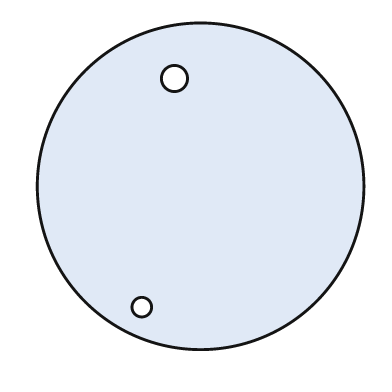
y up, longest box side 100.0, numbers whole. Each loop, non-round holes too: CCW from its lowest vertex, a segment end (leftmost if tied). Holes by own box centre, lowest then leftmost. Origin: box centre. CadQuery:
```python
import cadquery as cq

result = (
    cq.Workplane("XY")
    .moveTo(0.0, 0.0)
    .circle(50.0)
    .moveTo(-18.0, -37.0)
    .circle(3.0)
    .moveTo(-8.0, 33.0)
    .circle(4.0)
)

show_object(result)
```